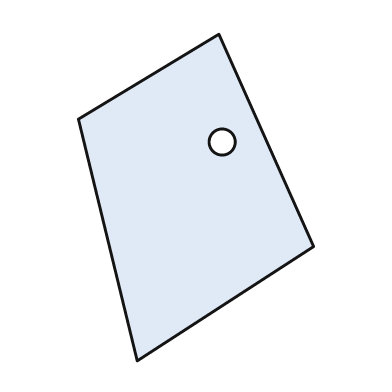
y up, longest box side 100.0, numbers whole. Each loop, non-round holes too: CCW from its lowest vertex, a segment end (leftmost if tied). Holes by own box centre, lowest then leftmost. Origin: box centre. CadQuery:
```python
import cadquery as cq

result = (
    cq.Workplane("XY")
    .moveTo(-18.0, -50.0)
    .lineTo(36.0, -15.0)
    .lineTo(7.0, 50.0)
    .lineTo(-36.0, 24.0)
    .close()
    .moveTo(8.0, 17.0)
    .circle(4.0)
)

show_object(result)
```